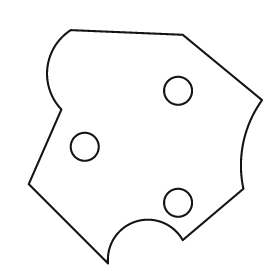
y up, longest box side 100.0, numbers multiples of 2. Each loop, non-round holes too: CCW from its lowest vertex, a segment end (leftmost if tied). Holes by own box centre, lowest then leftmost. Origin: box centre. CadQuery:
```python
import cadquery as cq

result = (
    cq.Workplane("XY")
    .moveTo(-16.0, -50.0)
    .threePointArc((-4.0, -32.0), (16.0, -40.0))
    .lineTo(42.0, -18.0)
    .threePointArc((42.0, 2.0), (50.0, 20.0))
    .lineTo(16.0, 48.0)
    .lineTo(-32.0, 50.0)
    .threePointArc((-42.0, 34.0), (-36.0, 16.0))
    .lineTo(-50.0, -16.0)
    .close()
    .moveTo(14.0, -24.0)
    .circle(6.0)
    .moveTo(-26.0, 0.0)
    .circle(6.0)
    .moveTo(14.0, 24.0)
    .circle(6.0)
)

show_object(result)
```